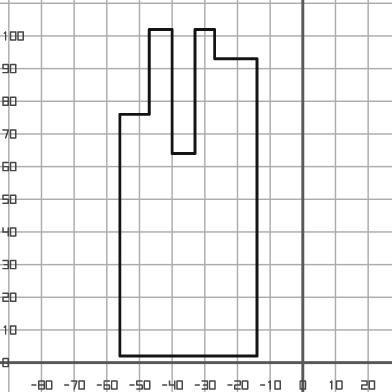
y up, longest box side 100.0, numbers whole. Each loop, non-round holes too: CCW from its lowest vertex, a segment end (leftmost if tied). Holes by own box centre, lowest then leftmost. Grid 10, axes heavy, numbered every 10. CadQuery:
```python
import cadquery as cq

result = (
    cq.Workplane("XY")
    .moveTo(-56.0, 2.0)
    .lineTo(-14.0, 2.0)
    .lineTo(-14.0, 93.0)
    .lineTo(-27.0, 93.0)
    .lineTo(-27.0, 102.0)
    .lineTo(-33.0, 102.0)
    .lineTo(-33.0, 64.0)
    .lineTo(-40.0, 64.0)
    .lineTo(-40.0, 102.0)
    .lineTo(-47.0, 102.0)
    .lineTo(-47.0, 76.0)
    .lineTo(-56.0, 76.0)
    .close()
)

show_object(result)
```